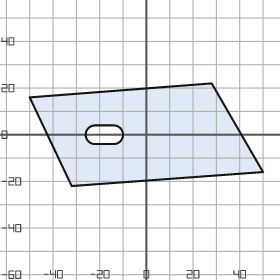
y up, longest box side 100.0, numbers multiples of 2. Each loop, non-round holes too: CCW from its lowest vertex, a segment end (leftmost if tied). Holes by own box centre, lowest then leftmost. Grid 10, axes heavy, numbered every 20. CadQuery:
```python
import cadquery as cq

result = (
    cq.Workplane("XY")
    .moveTo(-32.0, -22.0)
    .lineTo(50.0, -16.0)
    .lineTo(28.0, 22.0)
    .lineTo(-50.0, 16.0)
    .close()
    .moveTo(-22.0, -4.0)
    .lineTo(-14.0, -4.0)
    .threePointArc((-10.0, 0.0), (-14.0, 4.0))
    .lineTo(-22.0, 4.0)
    .threePointArc((-26.0, 0.0), (-22.0, -4.0))
    .close()
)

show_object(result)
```